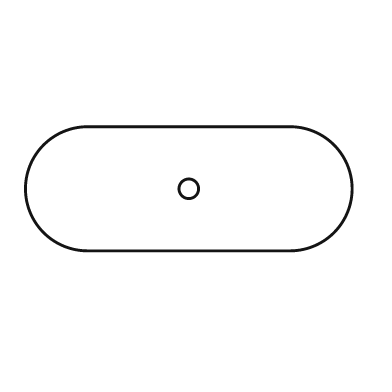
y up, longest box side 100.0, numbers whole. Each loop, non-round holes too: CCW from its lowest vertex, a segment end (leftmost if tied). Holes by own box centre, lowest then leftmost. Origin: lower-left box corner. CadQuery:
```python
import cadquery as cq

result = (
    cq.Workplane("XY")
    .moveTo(19.0, 0.0)
    .lineTo(81.0, 0.0)
    .threePointArc((100.0, 19.0), (81.0, 38.0))
    .lineTo(19.0, 38.0)
    .threePointArc((0.0, 19.0), (19.0, 0.0))
    .close()
    .moveTo(50.0, 19.0)
    .circle(3.0)
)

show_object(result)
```